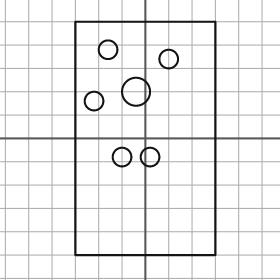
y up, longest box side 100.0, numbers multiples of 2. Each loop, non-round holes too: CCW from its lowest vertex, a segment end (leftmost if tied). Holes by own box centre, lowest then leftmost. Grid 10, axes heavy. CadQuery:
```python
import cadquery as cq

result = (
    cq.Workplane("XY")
    .moveTo(-30.0, -50.0)
    .lineTo(30.0, -50.0)
    .lineTo(30.0, 50.0)
    .lineTo(-30.0, 50.0)
    .close()
    .moveTo(-10.0, -8.0)
    .circle(4.0)
    .moveTo(2.0, -8.0)
    .circle(4.0)
    .moveTo(-22.0, 16.0)
    .circle(4.0)
    .moveTo(-4.0, 20.0)
    .circle(6.0)
    .moveTo(10.0, 34.0)
    .circle(4.0)
    .moveTo(-16.0, 38.0)
    .circle(4.0)
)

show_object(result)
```